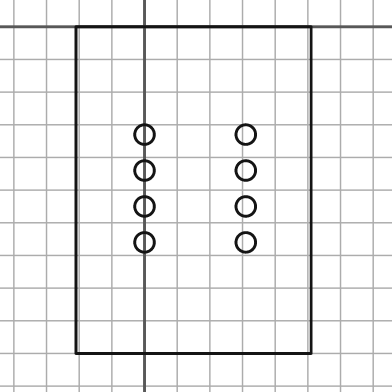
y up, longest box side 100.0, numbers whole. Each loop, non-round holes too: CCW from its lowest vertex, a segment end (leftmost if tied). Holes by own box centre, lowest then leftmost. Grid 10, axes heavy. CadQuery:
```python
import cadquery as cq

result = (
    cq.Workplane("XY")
    .moveTo(-21.0, -100.0)
    .lineTo(51.0, -100.0)
    .lineTo(51.0, 0.0)
    .lineTo(-21.0, 0.0)
    .close()
    .moveTo(0.0, -66.0)
    .circle(3.0)
    .moveTo(31.0, -66.0)
    .circle(3.0)
    .moveTo(0.0, -55.0)
    .circle(3.0)
    .moveTo(31.0, -55.0)
    .circle(3.0)
    .moveTo(0.0, -44.0)
    .circle(3.0)
    .moveTo(31.0, -44.0)
    .circle(3.0)
    .moveTo(0.0, -33.0)
    .circle(3.0)
    .moveTo(31.0, -33.0)
    .circle(3.0)
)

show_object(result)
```